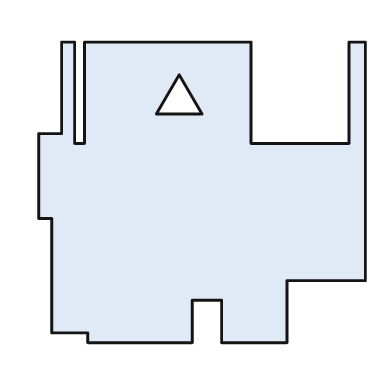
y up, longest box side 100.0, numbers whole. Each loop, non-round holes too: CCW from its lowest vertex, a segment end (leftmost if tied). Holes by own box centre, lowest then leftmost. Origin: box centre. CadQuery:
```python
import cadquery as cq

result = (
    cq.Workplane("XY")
    .moveTo(-35.0, -46.0)
    .lineTo(-3.0, -46.0)
    .lineTo(-3.0, -33.0)
    .lineTo(6.0, -33.0)
    .lineTo(6.0, -46.0)
    .lineTo(26.0, -46.0)
    .lineTo(26.0, -27.0)
    .lineTo(50.0, -27.0)
    .lineTo(50.0, 46.0)
    .lineTo(45.0, 46.0)
    .lineTo(45.0, 15.0)
    .lineTo(15.0, 15.0)
    .lineTo(15.0, 46.0)
    .lineTo(-36.0, 46.0)
    .lineTo(-36.0, 15.0)
    .lineTo(-39.0, 15.0)
    .lineTo(-39.0, 46.0)
    .lineTo(-43.0, 46.0)
    .lineTo(-43.0, 18.0)
    .lineTo(-50.0, 18.0)
    .lineTo(-50.0, -8.0)
    .lineTo(-46.0, -8.0)
    .lineTo(-46.0, -43.0)
    .lineTo(-35.0, -43.0)
    .close()
    .moveTo(-14.0, 24.0)
    .lineTo(0.0, 24.0)
    .lineTo(-7.0, 36.0)
    .close()
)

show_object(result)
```